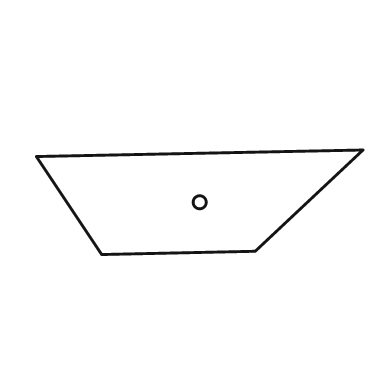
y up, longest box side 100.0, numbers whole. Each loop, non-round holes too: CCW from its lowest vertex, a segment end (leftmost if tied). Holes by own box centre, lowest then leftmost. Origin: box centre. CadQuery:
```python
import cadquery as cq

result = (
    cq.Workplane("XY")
    .moveTo(-30.0, -16.0)
    .lineTo(17.0, -15.0)
    .lineTo(50.0, 16.0)
    .lineTo(-50.0, 14.0)
    .close()
    .moveTo(0.0, 0.0)
    .circle(2.0)
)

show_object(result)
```